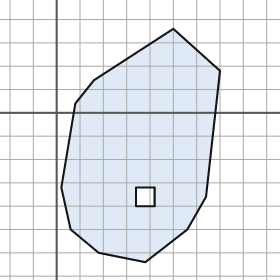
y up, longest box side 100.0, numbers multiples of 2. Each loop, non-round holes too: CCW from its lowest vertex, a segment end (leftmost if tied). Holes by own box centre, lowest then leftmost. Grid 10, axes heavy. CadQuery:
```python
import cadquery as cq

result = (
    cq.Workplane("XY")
    .moveTo(38.0, -64.0)
    .lineTo(56.0, -50.0)
    .lineTo(64.0, -36.0)
    .lineTo(70.0, 18.0)
    .lineTo(50.0, 36.0)
    .lineTo(16.0, 14.0)
    .lineTo(8.0, 4.0)
    .lineTo(2.0, -32.0)
    .lineTo(6.0, -50.0)
    .lineTo(18.0, -60.0)
    .close()
    .moveTo(34.0, -40.0)
    .lineTo(42.0, -40.0)
    .lineTo(42.0, -32.0)
    .lineTo(34.0, -32.0)
    .close()
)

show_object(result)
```